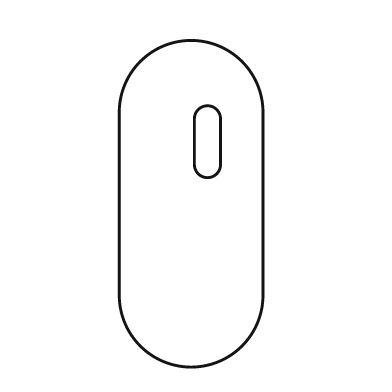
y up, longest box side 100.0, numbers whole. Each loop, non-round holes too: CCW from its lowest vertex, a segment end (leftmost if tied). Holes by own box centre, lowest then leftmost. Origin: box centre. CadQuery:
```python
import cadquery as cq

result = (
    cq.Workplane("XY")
    .moveTo(-22.0, -28.0)
    .threePointArc((0.0, -50.0), (22.0, -28.0))
    .lineTo(22.0, 28.0)
    .threePointArc((0.0, 50.0), (-22.0, 28.0))
    .close()
    .moveTo(1.0, 12.0)
    .threePointArc((5.0, 8.0), (9.0, 12.0))
    .lineTo(9.0, 26.0)
    .threePointArc((5.0, 30.0), (1.0, 26.0))
    .close()
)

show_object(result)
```